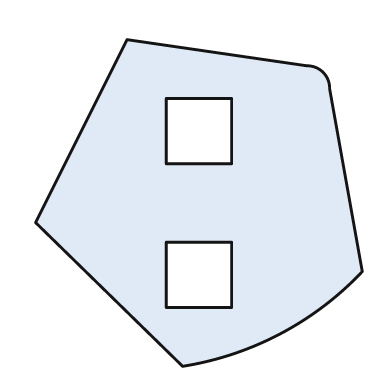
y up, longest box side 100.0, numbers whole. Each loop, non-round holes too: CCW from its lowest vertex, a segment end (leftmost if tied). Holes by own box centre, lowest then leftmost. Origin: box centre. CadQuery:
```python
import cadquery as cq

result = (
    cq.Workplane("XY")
    .moveTo(-5.0, -50.0)
    .threePointArc((25.0, -40.0), (50.0, -21.0))
    .lineTo(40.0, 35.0)
    .threePointArc((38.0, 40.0), (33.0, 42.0))
    .lineTo(-22.0, 50.0)
    .lineTo(-50.0, -6.0)
    .close()
    .moveTo(-10.0, -32.0)
    .lineTo(10.0, -32.0)
    .lineTo(10.0, -12.0)
    .lineTo(-10.0, -12.0)
    .close()
    .moveTo(-10.0, 12.0)
    .lineTo(10.0, 12.0)
    .lineTo(10.0, 32.0)
    .lineTo(-10.0, 32.0)
    .close()
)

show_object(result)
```